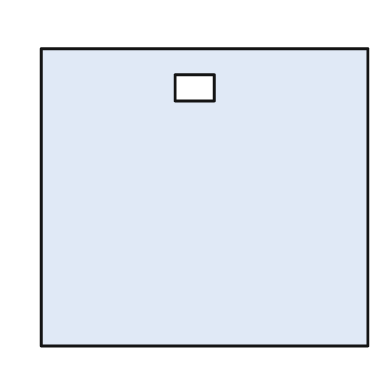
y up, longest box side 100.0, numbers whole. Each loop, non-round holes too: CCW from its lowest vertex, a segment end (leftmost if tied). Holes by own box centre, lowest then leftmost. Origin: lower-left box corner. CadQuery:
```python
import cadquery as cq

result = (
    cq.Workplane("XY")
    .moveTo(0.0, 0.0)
    .lineTo(100.0, 0.0)
    .lineTo(100.0, 91.0)
    .lineTo(0.0, 91.0)
    .close()
    .moveTo(41.0, 75.0)
    .lineTo(53.0, 75.0)
    .lineTo(53.0, 83.0)
    .lineTo(41.0, 83.0)
    .close()
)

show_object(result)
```